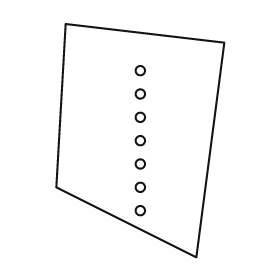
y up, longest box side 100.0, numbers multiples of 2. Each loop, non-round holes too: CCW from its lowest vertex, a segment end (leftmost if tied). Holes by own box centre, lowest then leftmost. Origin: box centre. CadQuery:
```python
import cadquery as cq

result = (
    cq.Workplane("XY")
    .moveTo(24.0, -50.0)
    .lineTo(36.0, 42.0)
    .lineTo(-32.0, 50.0)
    .lineTo(-36.0, -20.0)
    .close()
    .moveTo(0.0, -30.0)
    .circle(2.0)
    .moveTo(0.0, -20.0)
    .circle(2.0)
    .moveTo(0.0, -10.0)
    .circle(2.0)
    .moveTo(0.0, 0.0)
    .circle(2.0)
    .moveTo(0.0, 10.0)
    .circle(2.0)
    .moveTo(0.0, 20.0)
    .circle(2.0)
    .moveTo(0.0, 30.0)
    .circle(2.0)
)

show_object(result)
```